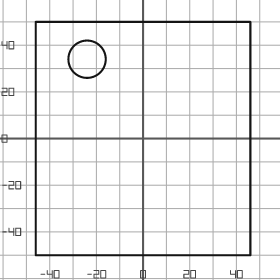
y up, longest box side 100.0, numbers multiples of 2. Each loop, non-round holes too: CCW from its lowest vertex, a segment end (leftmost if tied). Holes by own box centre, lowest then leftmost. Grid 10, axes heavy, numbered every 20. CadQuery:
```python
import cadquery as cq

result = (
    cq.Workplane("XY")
    .moveTo(-46.0, -50.0)
    .lineTo(46.0, -50.0)
    .lineTo(46.0, 50.0)
    .lineTo(-46.0, 50.0)
    .close()
    .moveTo(-24.0, 34.0)
    .circle(8.0)
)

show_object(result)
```